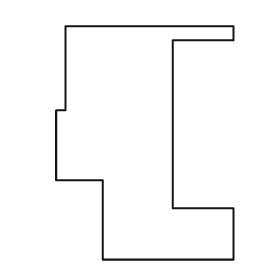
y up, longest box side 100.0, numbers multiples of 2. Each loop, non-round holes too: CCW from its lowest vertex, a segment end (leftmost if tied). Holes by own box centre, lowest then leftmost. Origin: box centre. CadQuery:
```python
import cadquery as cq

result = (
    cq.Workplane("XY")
    .moveTo(-18.0, -50.0)
    .lineTo(38.0, -50.0)
    .lineTo(38.0, -28.0)
    .lineTo(12.0, -28.0)
    .lineTo(12.0, 44.0)
    .lineTo(38.0, 44.0)
    .lineTo(38.0, 50.0)
    .lineTo(-34.0, 50.0)
    .lineTo(-34.0, 14.0)
    .lineTo(-38.0, 14.0)
    .lineTo(-38.0, -16.0)
    .lineTo(-18.0, -16.0)
    .close()
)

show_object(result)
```